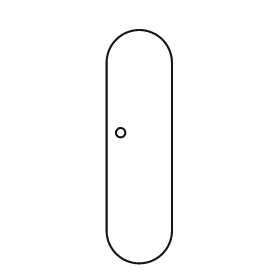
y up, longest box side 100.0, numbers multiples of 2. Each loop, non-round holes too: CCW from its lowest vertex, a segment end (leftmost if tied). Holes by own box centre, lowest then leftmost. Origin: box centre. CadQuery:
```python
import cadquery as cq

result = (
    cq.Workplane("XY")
    .moveTo(-14.0, -36.0)
    .threePointArc((0.0, -50.0), (14.0, -36.0))
    .lineTo(14.0, 36.0)
    .threePointArc((0.0, 50.0), (-14.0, 36.0))
    .close()
    .moveTo(-8.0, 6.0)
    .circle(2.0)
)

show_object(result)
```